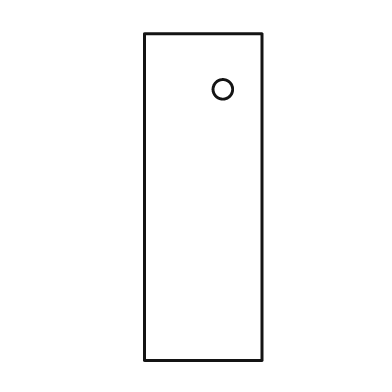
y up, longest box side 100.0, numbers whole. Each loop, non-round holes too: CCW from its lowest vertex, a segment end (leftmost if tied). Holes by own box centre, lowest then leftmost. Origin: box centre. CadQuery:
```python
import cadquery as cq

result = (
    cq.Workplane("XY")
    .moveTo(-18.0, -50.0)
    .lineTo(18.0, -50.0)
    .lineTo(18.0, 50.0)
    .lineTo(-18.0, 50.0)
    .close()
    .moveTo(6.0, 33.0)
    .circle(3.0)
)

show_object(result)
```